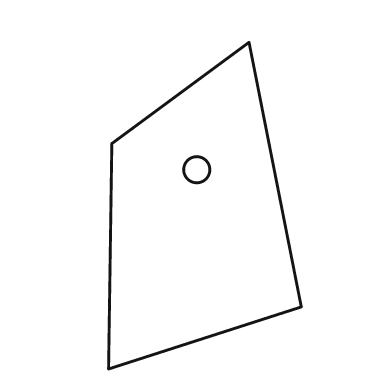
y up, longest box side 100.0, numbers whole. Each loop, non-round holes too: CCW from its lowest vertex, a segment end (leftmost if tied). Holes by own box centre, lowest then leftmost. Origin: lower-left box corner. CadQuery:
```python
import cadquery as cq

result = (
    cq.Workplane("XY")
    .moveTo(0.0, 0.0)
    .lineTo(59.0, 19.0)
    .lineTo(43.0, 100.0)
    .lineTo(1.0, 69.0)
    .close()
    .moveTo(27.0, 61.0)
    .circle(4.0)
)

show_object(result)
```